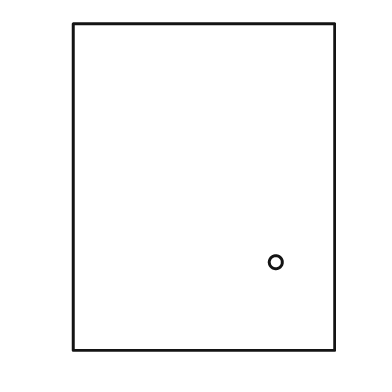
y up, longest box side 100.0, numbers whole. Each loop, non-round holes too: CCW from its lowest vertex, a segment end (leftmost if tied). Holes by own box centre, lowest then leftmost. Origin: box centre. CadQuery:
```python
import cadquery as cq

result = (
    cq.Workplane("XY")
    .moveTo(-40.0, -50.0)
    .lineTo(40.0, -50.0)
    .lineTo(40.0, 50.0)
    .lineTo(-40.0, 50.0)
    .close()
    .moveTo(22.0, -23.0)
    .circle(2.0)
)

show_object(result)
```